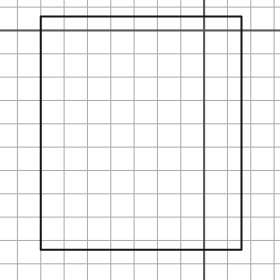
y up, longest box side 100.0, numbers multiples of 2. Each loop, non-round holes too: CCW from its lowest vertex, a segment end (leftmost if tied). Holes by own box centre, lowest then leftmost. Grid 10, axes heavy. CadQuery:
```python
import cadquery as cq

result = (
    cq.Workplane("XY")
    .moveTo(-70.0, -94.0)
    .lineTo(16.0, -94.0)
    .lineTo(16.0, 6.0)
    .lineTo(-70.0, 6.0)
    .close()
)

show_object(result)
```